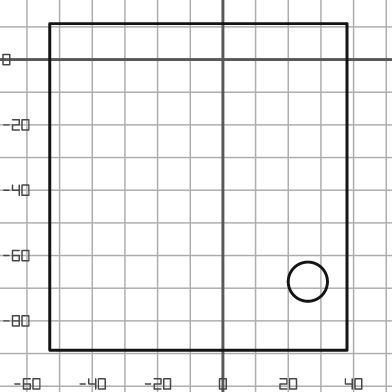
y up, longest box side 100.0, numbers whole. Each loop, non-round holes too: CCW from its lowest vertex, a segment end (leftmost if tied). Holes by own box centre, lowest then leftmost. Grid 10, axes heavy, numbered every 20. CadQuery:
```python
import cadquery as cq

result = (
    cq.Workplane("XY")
    .moveTo(-53.0, -89.0)
    .lineTo(38.0, -89.0)
    .lineTo(38.0, 11.0)
    .lineTo(-53.0, 11.0)
    .close()
    .moveTo(26.0, -68.0)
    .circle(6.0)
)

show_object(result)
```